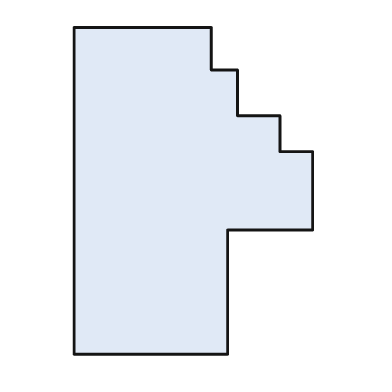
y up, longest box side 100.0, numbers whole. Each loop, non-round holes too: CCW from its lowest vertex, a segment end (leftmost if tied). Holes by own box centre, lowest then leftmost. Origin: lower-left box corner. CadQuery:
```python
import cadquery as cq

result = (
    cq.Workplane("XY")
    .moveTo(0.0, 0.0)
    .lineTo(47.0, 0.0)
    .lineTo(47.0, 38.0)
    .lineTo(73.0, 38.0)
    .lineTo(73.0, 62.0)
    .lineTo(63.0, 62.0)
    .lineTo(63.0, 73.0)
    .lineTo(50.0, 73.0)
    .lineTo(50.0, 87.0)
    .lineTo(42.0, 87.0)
    .lineTo(42.0, 100.0)
    .lineTo(0.0, 100.0)
    .close()
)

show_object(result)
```